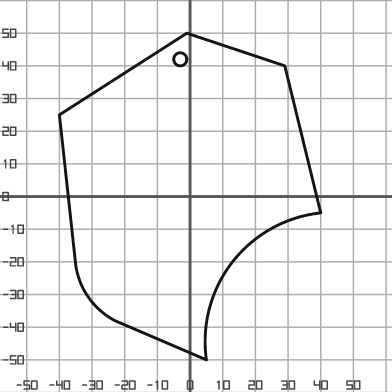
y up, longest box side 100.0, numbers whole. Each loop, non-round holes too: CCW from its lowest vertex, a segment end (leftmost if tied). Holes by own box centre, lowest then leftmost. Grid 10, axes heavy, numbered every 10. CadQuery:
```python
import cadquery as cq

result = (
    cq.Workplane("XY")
    .moveTo(5.0, -50.0)
    .threePointArc((13.0, -20.0), (40.0, -5.0))
    .lineTo(29.0, 40.0)
    .lineTo(-1.0, 50.0)
    .lineTo(-40.0, 25.0)
    .lineTo(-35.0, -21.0)
    .threePointArc((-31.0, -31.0), (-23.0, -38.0))
    .close()
    .moveTo(-3.0, 42.0)
    .circle(2.0)
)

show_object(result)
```